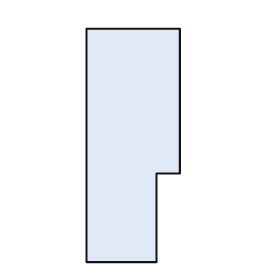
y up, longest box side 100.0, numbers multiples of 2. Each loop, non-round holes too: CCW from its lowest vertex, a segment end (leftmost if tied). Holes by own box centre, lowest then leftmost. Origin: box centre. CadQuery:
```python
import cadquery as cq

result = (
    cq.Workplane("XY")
    .moveTo(-20.0, -50.0)
    .lineTo(10.0, -50.0)
    .lineTo(10.0, -12.0)
    .lineTo(20.0, -12.0)
    .lineTo(20.0, 50.0)
    .lineTo(-20.0, 50.0)
    .close()
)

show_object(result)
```